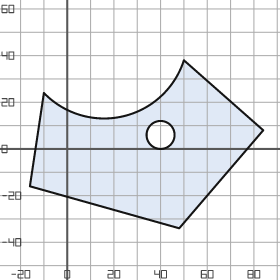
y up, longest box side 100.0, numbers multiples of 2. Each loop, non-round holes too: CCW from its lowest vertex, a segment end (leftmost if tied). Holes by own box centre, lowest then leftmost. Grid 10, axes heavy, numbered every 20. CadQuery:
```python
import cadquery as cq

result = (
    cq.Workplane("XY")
    .moveTo(48.0, -34.0)
    .lineTo(84.0, 8.0)
    .lineTo(50.0, 38.0)
    .threePointArc((24.0, 14.0), (-10.0, 24.0))
    .lineTo(-16.0, -16.0)
    .close()
    .moveTo(40.0, 6.0)
    .circle(6.0)
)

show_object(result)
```